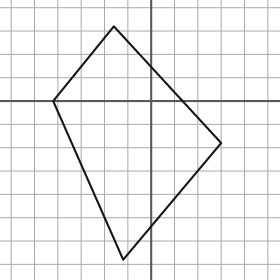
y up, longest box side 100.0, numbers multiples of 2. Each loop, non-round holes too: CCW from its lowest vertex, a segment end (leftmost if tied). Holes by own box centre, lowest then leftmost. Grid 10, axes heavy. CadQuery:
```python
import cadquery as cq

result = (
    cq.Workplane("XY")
    .moveTo(-12.0, -68.0)
    .lineTo(30.0, -18.0)
    .lineTo(-16.0, 32.0)
    .lineTo(-42.0, 0.0)
    .close()
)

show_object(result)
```